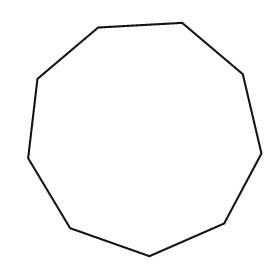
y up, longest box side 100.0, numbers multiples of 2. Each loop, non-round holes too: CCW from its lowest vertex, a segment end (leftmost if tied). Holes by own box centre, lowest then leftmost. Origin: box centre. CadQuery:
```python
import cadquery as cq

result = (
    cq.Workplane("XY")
    .moveTo(2.0, -50.0)
    .lineTo(34.0, -36.0)
    .lineTo(50.0, -6.0)
    .lineTo(42.0, 28.0)
    .lineTo(16.0, 50.0)
    .lineTo(-20.0, 48.0)
    .lineTo(-46.0, 26.0)
    .lineTo(-50.0, -8.0)
    .lineTo(-32.0, -38.0)
    .close()
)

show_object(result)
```